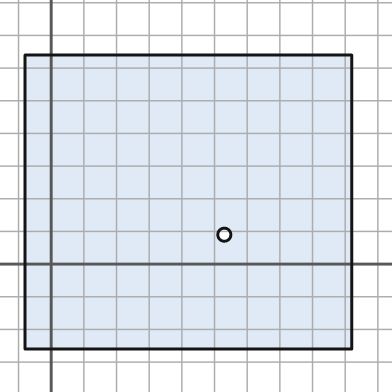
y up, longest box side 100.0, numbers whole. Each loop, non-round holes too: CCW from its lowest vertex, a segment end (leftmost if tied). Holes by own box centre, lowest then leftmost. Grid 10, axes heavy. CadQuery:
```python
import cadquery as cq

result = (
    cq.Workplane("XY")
    .moveTo(-8.0, -26.0)
    .lineTo(92.0, -26.0)
    .lineTo(92.0, 64.0)
    .lineTo(-8.0, 64.0)
    .close()
    .moveTo(53.0, 9.0)
    .circle(2.0)
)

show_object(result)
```